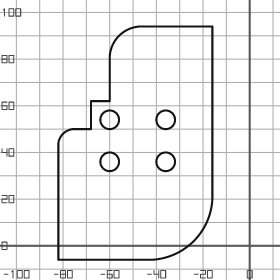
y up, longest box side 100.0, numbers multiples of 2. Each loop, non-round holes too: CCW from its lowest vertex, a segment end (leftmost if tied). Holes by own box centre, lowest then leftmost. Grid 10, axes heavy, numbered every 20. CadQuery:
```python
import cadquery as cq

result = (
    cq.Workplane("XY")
    .moveTo(-82.0, -6.0)
    .lineTo(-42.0, -6.0)
    .threePointArc((-24.0, 2.0), (-16.0, 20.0))
    .lineTo(-16.0, 94.0)
    .lineTo(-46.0, 94.0)
    .threePointArc((-56.0, 90.0), (-60.0, 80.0))
    .lineTo(-60.0, 62.0)
    .lineTo(-68.0, 62.0)
    .lineTo(-68.0, 50.0)
    .lineTo(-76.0, 50.0)
    .threePointArc((-80.0, 48.0), (-82.0, 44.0))
    .close()
    .moveTo(-60.0, 36.0)
    .circle(4.0)
    .moveTo(-36.0, 36.0)
    .circle(4.0)
    .moveTo(-60.0, 54.0)
    .circle(4.0)
    .moveTo(-36.0, 54.0)
    .circle(4.0)
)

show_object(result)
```